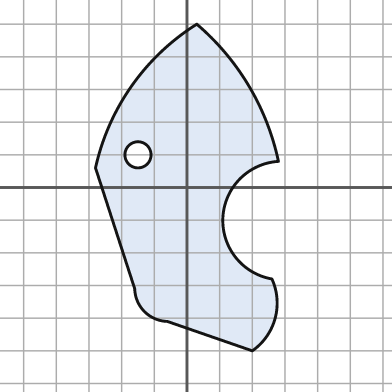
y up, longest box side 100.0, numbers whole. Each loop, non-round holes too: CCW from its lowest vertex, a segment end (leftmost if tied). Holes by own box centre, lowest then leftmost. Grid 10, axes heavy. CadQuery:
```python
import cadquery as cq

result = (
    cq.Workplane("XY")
    .moveTo(20.0, -50.0)
    .threePointArc((27.0, -40.0), (26.0, -28.0))
    .threePointArc((11.0, -9.0), (28.0, 8.0))
    .threePointArc((19.0, 31.0), (3.0, 50.0))
    .threePointArc((-17.0, 31.0), (-28.0, 6.0))
    .lineTo(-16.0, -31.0)
    .threePointArc((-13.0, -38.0), (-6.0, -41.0))
    .close()
    .moveTo(-15.0, 10.0)
    .circle(4.0)
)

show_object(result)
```